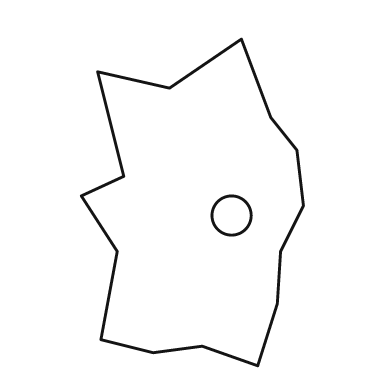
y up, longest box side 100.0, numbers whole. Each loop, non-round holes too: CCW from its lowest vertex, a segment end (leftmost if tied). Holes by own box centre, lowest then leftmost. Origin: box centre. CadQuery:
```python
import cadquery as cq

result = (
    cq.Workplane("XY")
    .moveTo(20.0, -50.0)
    .lineTo(26.0, -31.0)
    .lineTo(27.0, -15.0)
    .lineTo(34.0, -1.0)
    .lineTo(32.0, 16.0)
    .lineTo(24.0, 26.0)
    .lineTo(15.0, 50.0)
    .lineTo(-7.0, 35.0)
    .lineTo(-29.0, 40.0)
    .lineTo(-21.0, 8.0)
    .lineTo(-34.0, 2.0)
    .lineTo(-23.0, -15.0)
    .lineTo(-28.0, -42.0)
    .lineTo(-12.0, -46.0)
    .lineTo(3.0, -44.0)
    .close()
    .moveTo(12.0, -4.0)
    .circle(6.0)
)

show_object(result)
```